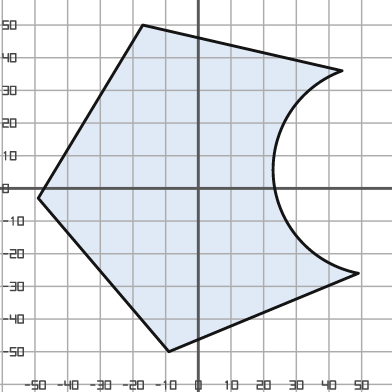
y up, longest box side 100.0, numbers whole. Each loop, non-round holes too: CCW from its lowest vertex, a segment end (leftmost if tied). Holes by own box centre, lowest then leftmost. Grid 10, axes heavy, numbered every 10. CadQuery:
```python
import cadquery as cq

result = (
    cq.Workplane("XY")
    .moveTo(-9.0, -50.0)
    .lineTo(49.0, -26.0)
    .threePointArc((23.0, 3.0), (44.0, 36.0))
    .lineTo(-17.0, 50.0)
    .lineTo(-49.0, -3.0)
    .close()
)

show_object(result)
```